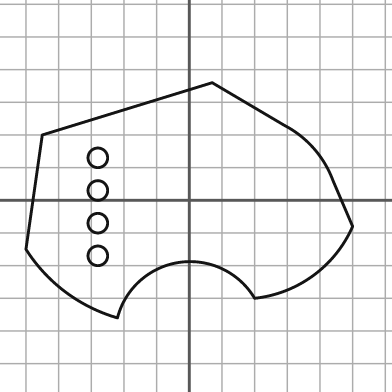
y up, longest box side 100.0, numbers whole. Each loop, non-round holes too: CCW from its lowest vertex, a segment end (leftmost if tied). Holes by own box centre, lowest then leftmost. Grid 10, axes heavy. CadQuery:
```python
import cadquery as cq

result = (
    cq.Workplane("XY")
    .moveTo(-22.0, -36.0)
    .threePointArc((-3.0, -19.0), (20.0, -30.0))
    .threePointArc((38.0, -23.0), (50.0, -8.0))
    .lineTo(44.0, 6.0)
    .threePointArc((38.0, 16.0), (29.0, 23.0))
    .lineTo(7.0, 36.0)
    .lineTo(-45.0, 20.0)
    .lineTo(-50.0, -15.0)
    .threePointArc((-38.0, -28.0), (-22.0, -36.0))
    .close()
    .moveTo(-28.0, -17.0)
    .circle(3.0)
    .moveTo(-28.0, -7.0)
    .circle(3.0)
    .moveTo(-28.0, 3.0)
    .circle(3.0)
    .moveTo(-28.0, 13.0)
    .circle(3.0)
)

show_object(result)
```